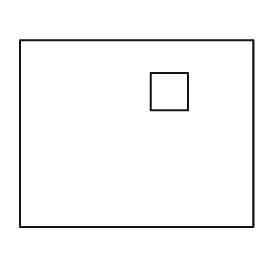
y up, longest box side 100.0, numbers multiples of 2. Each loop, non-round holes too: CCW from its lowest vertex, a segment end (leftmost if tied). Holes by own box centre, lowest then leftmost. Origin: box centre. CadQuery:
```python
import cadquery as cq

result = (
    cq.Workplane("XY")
    .moveTo(-50.0, -40.0)
    .lineTo(50.0, -40.0)
    .lineTo(50.0, 40.0)
    .lineTo(-50.0, 40.0)
    .close()
    .moveTo(6.0, 10.0)
    .lineTo(22.0, 10.0)
    .lineTo(22.0, 26.0)
    .lineTo(6.0, 26.0)
    .close()
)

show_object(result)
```